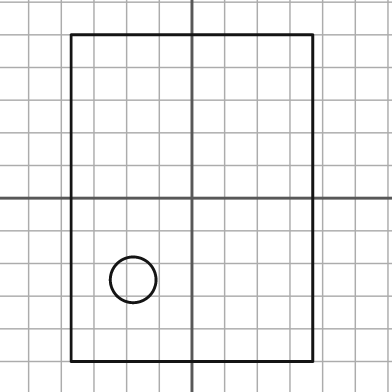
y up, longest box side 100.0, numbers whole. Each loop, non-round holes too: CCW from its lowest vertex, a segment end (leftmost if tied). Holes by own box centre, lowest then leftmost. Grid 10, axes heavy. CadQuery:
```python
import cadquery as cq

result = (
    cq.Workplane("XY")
    .moveTo(-37.0, -50.0)
    .lineTo(37.0, -50.0)
    .lineTo(37.0, 50.0)
    .lineTo(-37.0, 50.0)
    .close()
    .moveTo(-18.0, -25.0)
    .circle(7.0)
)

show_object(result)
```